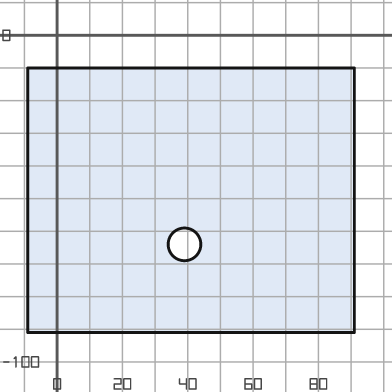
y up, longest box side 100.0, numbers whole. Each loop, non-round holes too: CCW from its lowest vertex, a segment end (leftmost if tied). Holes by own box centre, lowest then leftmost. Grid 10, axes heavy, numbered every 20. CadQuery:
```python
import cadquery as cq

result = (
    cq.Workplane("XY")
    .moveTo(-9.0, -91.0)
    .lineTo(91.0, -91.0)
    .lineTo(91.0, -10.0)
    .lineTo(-9.0, -10.0)
    .close()
    .moveTo(39.0, -64.0)
    .circle(5.0)
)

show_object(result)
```